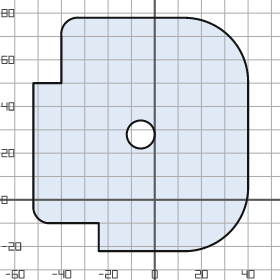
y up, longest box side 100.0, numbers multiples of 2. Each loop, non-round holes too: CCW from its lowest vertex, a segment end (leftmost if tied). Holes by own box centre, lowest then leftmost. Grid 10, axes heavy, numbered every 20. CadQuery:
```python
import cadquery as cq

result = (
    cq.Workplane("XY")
    .moveTo(-24.0, -22.0)
    .lineTo(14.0, -22.0)
    .threePointArc((32.0, -14.0), (40.0, 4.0))
    .lineTo(40.0, 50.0)
    .threePointArc((32.0, 70.0), (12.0, 78.0))
    .lineTo(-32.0, 78.0)
    .threePointArc((-38.0, 76.0), (-40.0, 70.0))
    .lineTo(-40.0, 50.0)
    .lineTo(-52.0, 50.0)
    .lineTo(-52.0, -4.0)
    .threePointArc((-50.0, -8.0), (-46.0, -10.0))
    .lineTo(-24.0, -10.0)
    .close()
    .moveTo(-6.0, 28.0)
    .circle(6.0)
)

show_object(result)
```